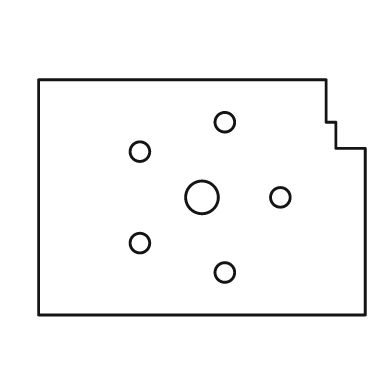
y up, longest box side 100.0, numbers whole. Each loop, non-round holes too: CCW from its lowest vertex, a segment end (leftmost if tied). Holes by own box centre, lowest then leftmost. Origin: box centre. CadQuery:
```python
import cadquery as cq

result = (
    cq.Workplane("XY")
    .moveTo(-50.0, -36.0)
    .lineTo(50.0, -36.0)
    .lineTo(50.0, 15.0)
    .lineTo(41.0, 15.0)
    .lineTo(41.0, 23.0)
    .lineTo(38.0, 23.0)
    .lineTo(38.0, 36.0)
    .lineTo(-50.0, 36.0)
    .close()
    .moveTo(7.0, -23.0)
    .circle(3.0)
    .moveTo(-19.0, -14.0)
    .circle(3.0)
    .moveTo(0.0, 0.0)
    .circle(5.0)
    .moveTo(24.0, 0.0)
    .circle(3.0)
    .moveTo(-19.0, 14.0)
    .circle(3.0)
    .moveTo(7.0, 23.0)
    .circle(3.0)
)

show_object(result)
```